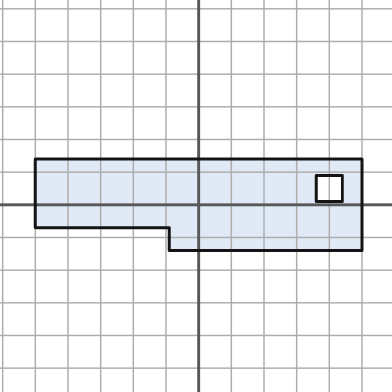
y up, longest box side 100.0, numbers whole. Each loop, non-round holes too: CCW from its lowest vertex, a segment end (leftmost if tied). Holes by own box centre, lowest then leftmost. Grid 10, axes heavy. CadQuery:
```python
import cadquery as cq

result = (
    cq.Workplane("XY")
    .moveTo(-9.0, -14.0)
    .lineTo(50.0, -14.0)
    .lineTo(50.0, 14.0)
    .lineTo(-50.0, 14.0)
    .lineTo(-50.0, -7.0)
    .lineTo(-9.0, -7.0)
    .close()
    .moveTo(36.0, 1.0)
    .lineTo(44.0, 1.0)
    .lineTo(44.0, 9.0)
    .lineTo(36.0, 9.0)
    .close()
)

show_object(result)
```